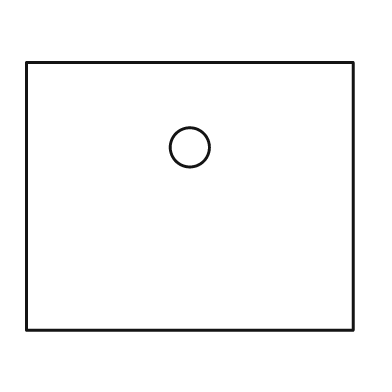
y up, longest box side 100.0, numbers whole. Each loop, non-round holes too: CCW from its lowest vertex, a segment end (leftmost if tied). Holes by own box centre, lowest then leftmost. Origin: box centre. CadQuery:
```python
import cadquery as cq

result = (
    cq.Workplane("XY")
    .moveTo(-50.0, -41.0)
    .lineTo(50.0, -41.0)
    .lineTo(50.0, 41.0)
    .lineTo(-50.0, 41.0)
    .close()
    .moveTo(0.0, 15.0)
    .circle(6.0)
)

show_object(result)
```